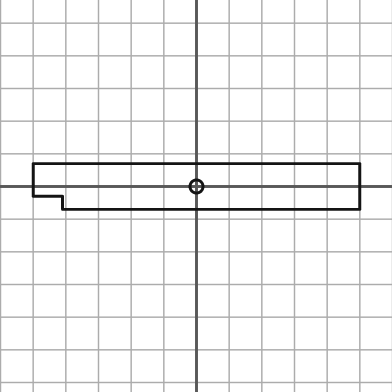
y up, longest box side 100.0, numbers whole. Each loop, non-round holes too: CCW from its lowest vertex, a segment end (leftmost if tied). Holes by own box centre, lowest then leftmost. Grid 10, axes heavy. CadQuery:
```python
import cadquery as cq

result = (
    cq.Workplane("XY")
    .moveTo(-41.0, -7.0)
    .lineTo(50.0, -7.0)
    .lineTo(50.0, 7.0)
    .lineTo(-50.0, 7.0)
    .lineTo(-50.0, -3.0)
    .lineTo(-41.0, -3.0)
    .close()
    .moveTo(0.0, 0.0)
    .circle(2.0)
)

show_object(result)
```